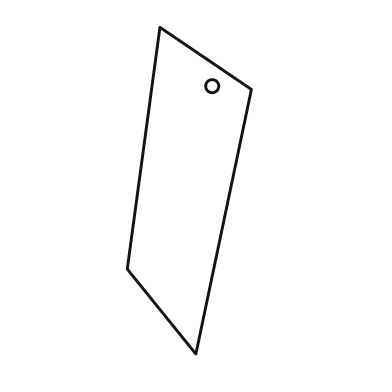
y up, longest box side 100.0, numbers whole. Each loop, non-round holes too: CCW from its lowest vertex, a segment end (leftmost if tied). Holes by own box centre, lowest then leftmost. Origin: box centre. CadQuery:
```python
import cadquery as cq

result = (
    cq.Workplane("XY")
    .moveTo(2.0, -50.0)
    .lineTo(19.0, 31.0)
    .lineTo(-9.0, 50.0)
    .lineTo(-19.0, -24.0)
    .close()
    .moveTo(7.0, 32.0)
    .circle(2.0)
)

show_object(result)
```